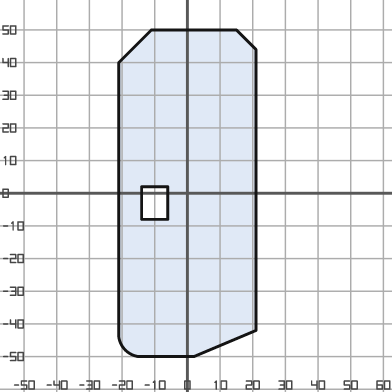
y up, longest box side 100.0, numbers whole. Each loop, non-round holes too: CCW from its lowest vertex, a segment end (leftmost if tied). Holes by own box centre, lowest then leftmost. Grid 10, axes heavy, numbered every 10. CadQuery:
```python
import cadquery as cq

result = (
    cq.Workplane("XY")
    .moveTo(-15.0, -50.0)
    .lineTo(2.0, -50.0)
    .lineTo(21.0, -42.0)
    .lineTo(21.0, 44.0)
    .lineTo(15.0, 50.0)
    .lineTo(-11.0, 50.0)
    .lineTo(-21.0, 40.0)
    .lineTo(-21.0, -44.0)
    .threePointArc((-19.0, -48.0), (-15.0, -50.0))
    .close()
    .moveTo(-14.0, -8.0)
    .lineTo(-6.0, -8.0)
    .lineTo(-6.0, 2.0)
    .lineTo(-14.0, 2.0)
    .close()
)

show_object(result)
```